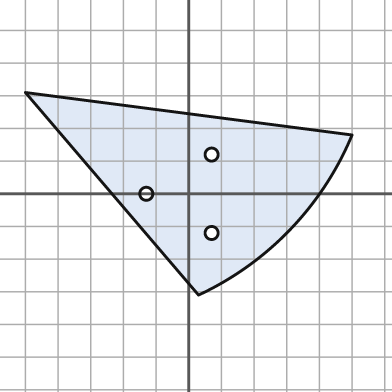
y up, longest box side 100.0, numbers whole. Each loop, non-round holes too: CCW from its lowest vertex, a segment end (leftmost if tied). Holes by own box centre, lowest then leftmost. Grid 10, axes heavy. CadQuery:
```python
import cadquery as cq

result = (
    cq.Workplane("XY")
    .moveTo(3.0, -31.0)
    .threePointArc((31.0, -11.0), (50.0, 18.0))
    .lineTo(-50.0, 31.0)
    .close()
    .moveTo(7.0, -12.0)
    .circle(2.0)
    .moveTo(-13.0, 0.0)
    .circle(2.0)
    .moveTo(7.0, 12.0)
    .circle(2.0)
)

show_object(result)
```